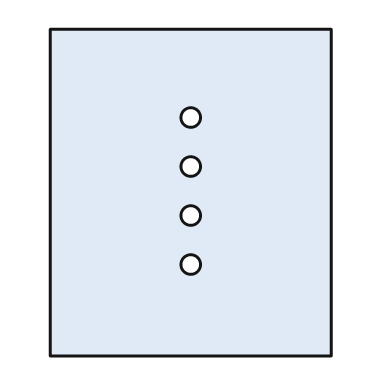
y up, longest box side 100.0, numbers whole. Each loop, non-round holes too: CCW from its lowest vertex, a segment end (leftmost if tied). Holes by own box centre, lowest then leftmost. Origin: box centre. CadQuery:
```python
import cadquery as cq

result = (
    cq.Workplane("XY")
    .moveTo(-43.0, -50.0)
    .lineTo(43.0, -50.0)
    .lineTo(43.0, 50.0)
    .lineTo(-43.0, 50.0)
    .close()
    .moveTo(0.0, -22.0)
    .circle(3.0)
    .moveTo(0.0, -7.0)
    .circle(3.0)
    .moveTo(0.0, 8.0)
    .circle(3.0)
    .moveTo(0.0, 23.0)
    .circle(3.0)
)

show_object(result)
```